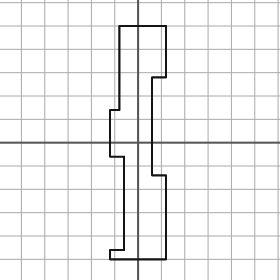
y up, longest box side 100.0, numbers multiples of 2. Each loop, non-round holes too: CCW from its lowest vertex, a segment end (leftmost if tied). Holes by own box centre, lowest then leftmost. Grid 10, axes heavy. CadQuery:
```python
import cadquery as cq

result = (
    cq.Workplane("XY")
    .moveTo(-12.0, -50.0)
    .lineTo(12.0, -50.0)
    .lineTo(12.0, -14.0)
    .lineTo(6.0, -14.0)
    .lineTo(6.0, 28.0)
    .lineTo(12.0, 28.0)
    .lineTo(12.0, 50.0)
    .lineTo(-8.0, 50.0)
    .lineTo(-8.0, 14.0)
    .lineTo(-12.0, 14.0)
    .lineTo(-12.0, -6.0)
    .lineTo(-6.0, -6.0)
    .lineTo(-6.0, -46.0)
    .lineTo(-12.0, -46.0)
    .close()
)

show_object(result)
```